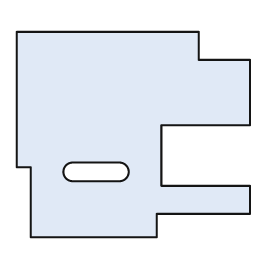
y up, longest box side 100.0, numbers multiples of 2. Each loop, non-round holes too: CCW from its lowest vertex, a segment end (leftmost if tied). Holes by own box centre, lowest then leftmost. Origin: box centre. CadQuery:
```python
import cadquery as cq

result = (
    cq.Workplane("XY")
    .moveTo(-44.0, -44.0)
    .lineTo(10.0, -44.0)
    .lineTo(10.0, -34.0)
    .lineTo(50.0, -34.0)
    .lineTo(50.0, -22.0)
    .lineTo(12.0, -22.0)
    .lineTo(12.0, 4.0)
    .lineTo(50.0, 4.0)
    .lineTo(50.0, 32.0)
    .lineTo(28.0, 32.0)
    .lineTo(28.0, 44.0)
    .lineTo(-50.0, 44.0)
    .lineTo(-50.0, -14.0)
    .lineTo(-44.0, -14.0)
    .close()
    .moveTo(-26.0, -20.0)
    .lineTo(-6.0, -20.0)
    .threePointArc((-2.0, -16.0), (-6.0, -12.0))
    .lineTo(-26.0, -12.0)
    .threePointArc((-30.0, -16.0), (-26.0, -20.0))
    .close()
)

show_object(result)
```